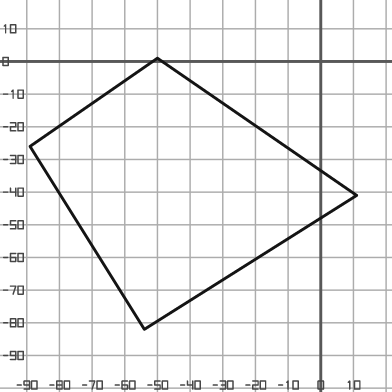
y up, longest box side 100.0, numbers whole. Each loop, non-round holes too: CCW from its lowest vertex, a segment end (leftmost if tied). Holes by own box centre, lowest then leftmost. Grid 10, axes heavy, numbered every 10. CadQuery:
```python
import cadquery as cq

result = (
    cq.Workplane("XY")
    .moveTo(-54.0, -82.0)
    .lineTo(11.0, -41.0)
    .lineTo(-50.0, 1.0)
    .lineTo(-89.0, -26.0)
    .close()
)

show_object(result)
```